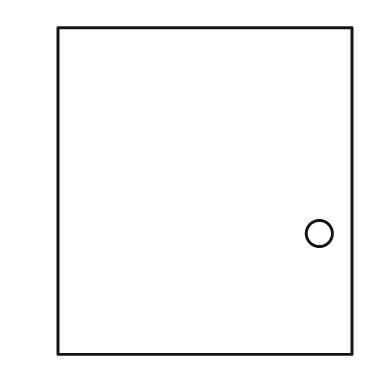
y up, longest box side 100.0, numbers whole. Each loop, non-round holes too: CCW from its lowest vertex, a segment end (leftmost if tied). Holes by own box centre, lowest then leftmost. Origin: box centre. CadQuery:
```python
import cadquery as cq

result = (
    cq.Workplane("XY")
    .moveTo(-45.0, -50.0)
    .lineTo(45.0, -50.0)
    .lineTo(45.0, 50.0)
    .lineTo(-45.0, 50.0)
    .close()
    .moveTo(35.0, -13.0)
    .circle(4.0)
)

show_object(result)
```